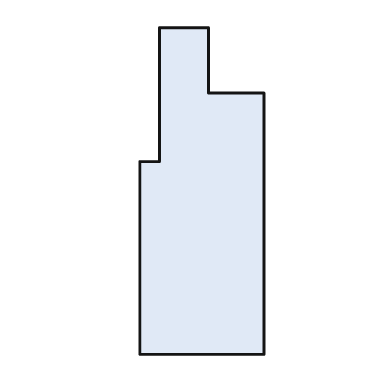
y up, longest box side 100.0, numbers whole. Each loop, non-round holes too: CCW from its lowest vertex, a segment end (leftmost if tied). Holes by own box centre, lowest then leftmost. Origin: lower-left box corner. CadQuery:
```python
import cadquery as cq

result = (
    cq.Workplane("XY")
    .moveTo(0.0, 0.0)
    .lineTo(38.0, 0.0)
    .lineTo(38.0, 80.0)
    .lineTo(21.0, 80.0)
    .lineTo(21.0, 100.0)
    .lineTo(6.0, 100.0)
    .lineTo(6.0, 59.0)
    .lineTo(0.0, 59.0)
    .close()
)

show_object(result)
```